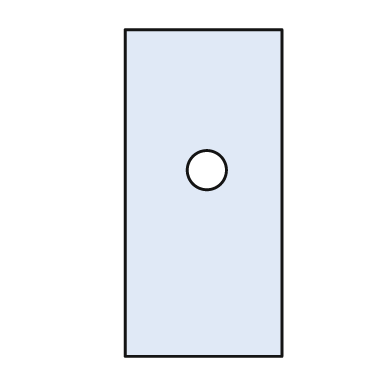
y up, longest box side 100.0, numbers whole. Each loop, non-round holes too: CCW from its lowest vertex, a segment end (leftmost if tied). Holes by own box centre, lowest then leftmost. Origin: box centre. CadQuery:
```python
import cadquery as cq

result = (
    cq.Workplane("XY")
    .moveTo(-24.0, -50.0)
    .lineTo(24.0, -50.0)
    .lineTo(24.0, 50.0)
    .lineTo(-24.0, 50.0)
    .close()
    .moveTo(1.0, 7.0)
    .circle(6.0)
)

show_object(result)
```